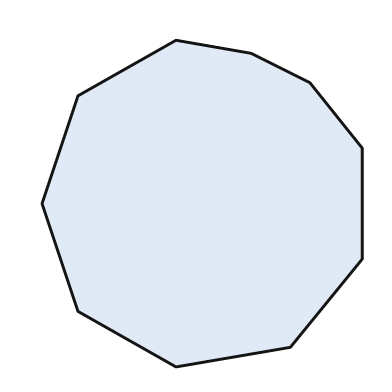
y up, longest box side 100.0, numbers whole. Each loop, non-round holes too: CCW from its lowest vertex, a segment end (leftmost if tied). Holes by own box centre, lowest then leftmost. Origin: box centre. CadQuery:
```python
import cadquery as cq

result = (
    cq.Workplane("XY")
    .moveTo(-8.0, -50.0)
    .lineTo(27.0, -44.0)
    .lineTo(49.0, -17.0)
    .lineTo(49.0, 17.0)
    .lineTo(33.0, 37.0)
    .lineTo(15.0, 46.0)
    .lineTo(-8.0, 50.0)
    .lineTo(-38.0, 33.0)
    .lineTo(-49.0, 0.0)
    .lineTo(-38.0, -33.0)
    .close()
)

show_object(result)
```